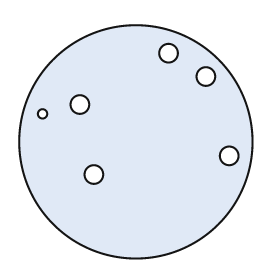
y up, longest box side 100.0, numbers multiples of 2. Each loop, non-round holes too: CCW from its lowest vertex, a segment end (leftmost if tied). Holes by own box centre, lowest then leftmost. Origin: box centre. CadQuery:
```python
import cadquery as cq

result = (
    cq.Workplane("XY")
    .moveTo(0.0, 0.0)
    .circle(50.0)
    .moveTo(-18.0, -14.0)
    .circle(4.0)
    .moveTo(40.0, -6.0)
    .circle(4.0)
    .moveTo(-40.0, 12.0)
    .circle(2.0)
    .moveTo(-24.0, 16.0)
    .circle(4.0)
    .moveTo(30.0, 28.0)
    .circle(4.0)
    .moveTo(14.0, 38.0)
    .circle(4.0)
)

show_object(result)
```